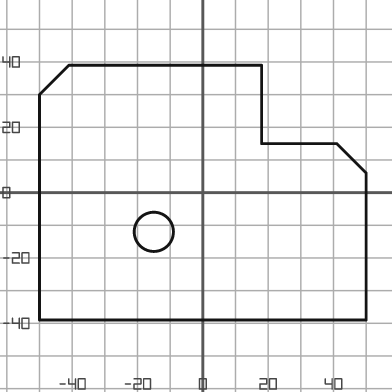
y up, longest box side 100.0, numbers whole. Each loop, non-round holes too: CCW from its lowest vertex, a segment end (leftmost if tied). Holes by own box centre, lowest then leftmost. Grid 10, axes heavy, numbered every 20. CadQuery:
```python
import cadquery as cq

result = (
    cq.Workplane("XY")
    .moveTo(-50.0, -39.0)
    .lineTo(50.0, -39.0)
    .lineTo(50.0, 6.0)
    .lineTo(41.0, 15.0)
    .lineTo(18.0, 15.0)
    .lineTo(18.0, 39.0)
    .lineTo(-41.0, 39.0)
    .lineTo(-50.0, 30.0)
    .close()
    .moveTo(-15.0, -12.0)
    .circle(6.0)
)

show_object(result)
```